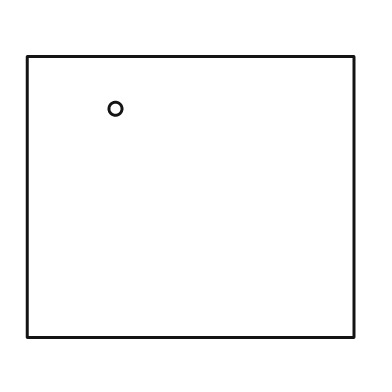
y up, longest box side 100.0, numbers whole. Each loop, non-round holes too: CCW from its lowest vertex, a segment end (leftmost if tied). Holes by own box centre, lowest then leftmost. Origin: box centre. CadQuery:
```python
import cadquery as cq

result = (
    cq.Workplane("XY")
    .moveTo(-50.0, -43.0)
    .lineTo(50.0, -43.0)
    .lineTo(50.0, 43.0)
    .lineTo(-50.0, 43.0)
    .close()
    .moveTo(-23.0, 27.0)
    .circle(2.0)
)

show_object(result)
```